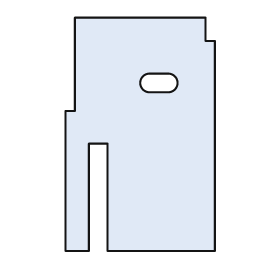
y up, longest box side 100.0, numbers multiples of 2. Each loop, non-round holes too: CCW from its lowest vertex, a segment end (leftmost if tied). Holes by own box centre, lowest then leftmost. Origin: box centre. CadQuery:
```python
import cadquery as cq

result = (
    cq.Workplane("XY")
    .moveTo(-32.0, -50.0)
    .lineTo(-22.0, -50.0)
    .lineTo(-22.0, -4.0)
    .lineTo(-14.0, -4.0)
    .lineTo(-14.0, -50.0)
    .lineTo(32.0, -50.0)
    .lineTo(32.0, 40.0)
    .lineTo(28.0, 40.0)
    .lineTo(28.0, 50.0)
    .lineTo(-28.0, 50.0)
    .lineTo(-28.0, 10.0)
    .lineTo(-32.0, 10.0)
    .close()
    .moveTo(4.0, 18.0)
    .lineTo(12.0, 18.0)
    .threePointArc((16.0, 22.0), (12.0, 26.0))
    .lineTo(4.0, 26.0)
    .threePointArc((0.0, 22.0), (4.0, 18.0))
    .close()
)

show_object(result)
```